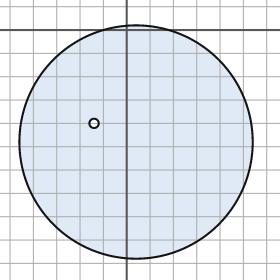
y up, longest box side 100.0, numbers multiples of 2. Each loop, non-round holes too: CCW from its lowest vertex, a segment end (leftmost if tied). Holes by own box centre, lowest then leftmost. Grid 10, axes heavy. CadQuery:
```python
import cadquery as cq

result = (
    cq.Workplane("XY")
    .moveTo(4.0, -48.0)
    .circle(50.0)
    .moveTo(-14.0, -40.0)
    .circle(2.0)
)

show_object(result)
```